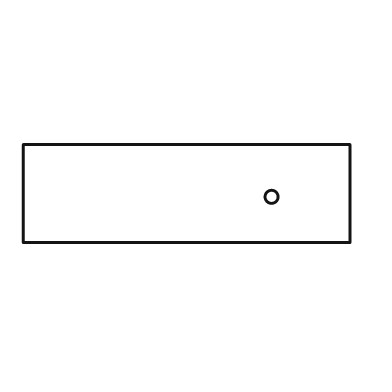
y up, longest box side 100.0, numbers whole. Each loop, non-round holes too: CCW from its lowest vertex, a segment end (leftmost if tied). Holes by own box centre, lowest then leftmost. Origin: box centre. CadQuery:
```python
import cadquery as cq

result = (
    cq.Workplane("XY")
    .moveTo(-50.0, -15.0)
    .lineTo(50.0, -15.0)
    .lineTo(50.0, 15.0)
    .lineTo(-50.0, 15.0)
    .close()
    .moveTo(26.0, -1.0)
    .circle(2.0)
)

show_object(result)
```